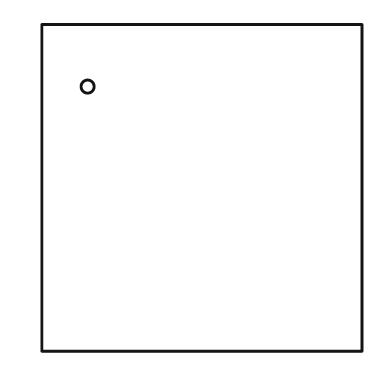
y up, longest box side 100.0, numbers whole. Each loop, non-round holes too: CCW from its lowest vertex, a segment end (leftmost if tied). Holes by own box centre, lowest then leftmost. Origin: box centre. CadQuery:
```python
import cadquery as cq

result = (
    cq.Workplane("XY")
    .moveTo(-49.0, -50.0)
    .lineTo(49.0, -50.0)
    .lineTo(49.0, 50.0)
    .lineTo(-49.0, 50.0)
    .close()
    .moveTo(-35.0, 31.0)
    .circle(2.0)
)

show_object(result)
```